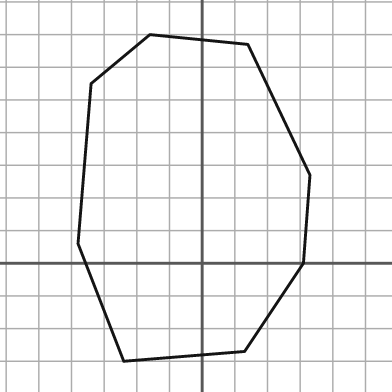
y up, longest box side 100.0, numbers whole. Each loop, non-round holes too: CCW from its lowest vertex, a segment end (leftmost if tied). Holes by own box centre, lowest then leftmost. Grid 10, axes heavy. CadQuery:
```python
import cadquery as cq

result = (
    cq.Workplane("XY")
    .moveTo(-24.0, -30.0)
    .lineTo(13.0, -27.0)
    .lineTo(31.0, 0.0)
    .lineTo(33.0, 27.0)
    .lineTo(14.0, 67.0)
    .lineTo(-16.0, 70.0)
    .lineTo(-34.0, 55.0)
    .lineTo(-38.0, 6.0)
    .close()
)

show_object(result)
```